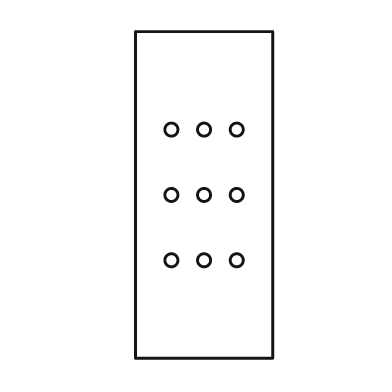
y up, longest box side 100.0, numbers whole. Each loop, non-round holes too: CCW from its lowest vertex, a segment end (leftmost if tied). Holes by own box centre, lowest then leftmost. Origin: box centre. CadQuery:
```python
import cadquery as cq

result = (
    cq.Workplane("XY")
    .moveTo(-21.0, -50.0)
    .lineTo(21.0, -50.0)
    .lineTo(21.0, 50.0)
    .lineTo(-21.0, 50.0)
    .close()
    .moveTo(-10.0, -20.0)
    .circle(2.0)
    .moveTo(0.0, -20.0)
    .circle(2.0)
    .moveTo(10.0, -20.0)
    .circle(2.0)
    .moveTo(-10.0, 0.0)
    .circle(2.0)
    .moveTo(0.0, 0.0)
    .circle(2.0)
    .moveTo(10.0, 0.0)
    .circle(2.0)
    .moveTo(-10.0, 20.0)
    .circle(2.0)
    .moveTo(0.0, 20.0)
    .circle(2.0)
    .moveTo(10.0, 20.0)
    .circle(2.0)
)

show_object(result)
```